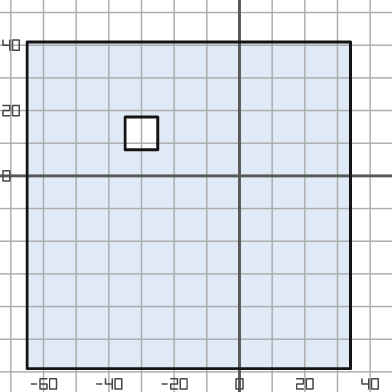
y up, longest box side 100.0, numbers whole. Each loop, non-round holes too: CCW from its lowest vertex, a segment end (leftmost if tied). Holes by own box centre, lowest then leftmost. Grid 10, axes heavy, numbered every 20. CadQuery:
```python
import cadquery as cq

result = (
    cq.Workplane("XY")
    .moveTo(-65.0, -59.0)
    .lineTo(34.0, -59.0)
    .lineTo(34.0, 41.0)
    .lineTo(-65.0, 41.0)
    .close()
    .moveTo(-35.0, 8.0)
    .lineTo(-25.0, 8.0)
    .lineTo(-25.0, 18.0)
    .lineTo(-35.0, 18.0)
    .close()
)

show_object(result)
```